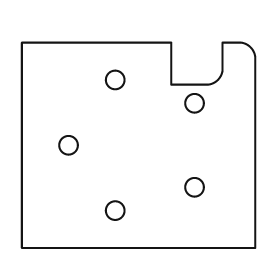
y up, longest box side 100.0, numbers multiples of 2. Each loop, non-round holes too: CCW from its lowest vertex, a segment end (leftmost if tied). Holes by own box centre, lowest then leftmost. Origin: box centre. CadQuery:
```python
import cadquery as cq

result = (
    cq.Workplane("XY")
    .moveTo(-50.0, -44.0)
    .lineTo(50.0, -44.0)
    .lineTo(50.0, 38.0)
    .threePointArc((48.0, 42.0), (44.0, 44.0))
    .lineTo(36.0, 44.0)
    .lineTo(36.0, 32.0)
    .threePointArc((34.0, 28.0), (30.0, 26.0))
    .lineTo(14.0, 26.0)
    .lineTo(14.0, 44.0)
    .lineTo(-50.0, 44.0)
    .close()
    .moveTo(-10.0, -28.0)
    .circle(4.0)
    .moveTo(24.0, -18.0)
    .circle(4.0)
    .moveTo(-30.0, 0.0)
    .circle(4.0)
    .moveTo(24.0, 18.0)
    .circle(4.0)
    .moveTo(-10.0, 28.0)
    .circle(4.0)
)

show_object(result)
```